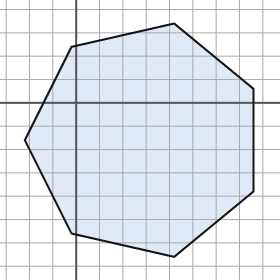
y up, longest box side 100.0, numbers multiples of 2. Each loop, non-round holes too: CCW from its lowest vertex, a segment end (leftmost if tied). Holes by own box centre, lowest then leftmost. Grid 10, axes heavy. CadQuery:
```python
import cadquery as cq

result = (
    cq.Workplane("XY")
    .moveTo(42.0, -66.0)
    .lineTo(76.0, -38.0)
    .lineTo(76.0, 6.0)
    .lineTo(42.0, 34.0)
    .lineTo(-2.0, 24.0)
    .lineTo(-22.0, -16.0)
    .lineTo(-2.0, -56.0)
    .close()
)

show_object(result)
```